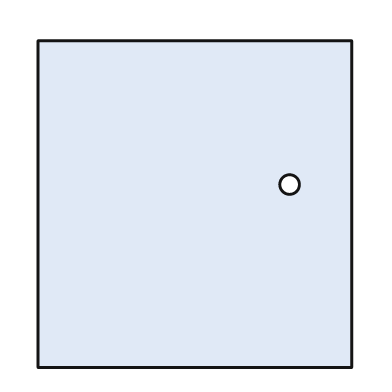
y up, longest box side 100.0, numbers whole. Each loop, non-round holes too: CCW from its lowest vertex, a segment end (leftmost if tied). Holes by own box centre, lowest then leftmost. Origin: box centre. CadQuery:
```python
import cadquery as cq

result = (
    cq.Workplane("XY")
    .moveTo(-48.0, -50.0)
    .lineTo(48.0, -50.0)
    .lineTo(48.0, 50.0)
    .lineTo(-48.0, 50.0)
    .close()
    .moveTo(29.0, 6.0)
    .circle(3.0)
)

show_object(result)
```